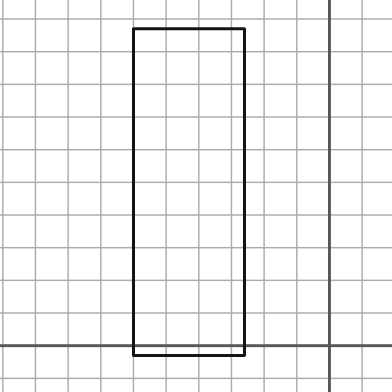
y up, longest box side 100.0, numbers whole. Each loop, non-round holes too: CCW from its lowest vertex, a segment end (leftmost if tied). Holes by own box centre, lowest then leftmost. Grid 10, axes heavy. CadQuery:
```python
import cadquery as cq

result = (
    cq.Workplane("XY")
    .moveTo(-60.0, -3.0)
    .lineTo(-26.0, -3.0)
    .lineTo(-26.0, 97.0)
    .lineTo(-60.0, 97.0)
    .close()
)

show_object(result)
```